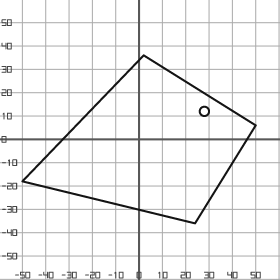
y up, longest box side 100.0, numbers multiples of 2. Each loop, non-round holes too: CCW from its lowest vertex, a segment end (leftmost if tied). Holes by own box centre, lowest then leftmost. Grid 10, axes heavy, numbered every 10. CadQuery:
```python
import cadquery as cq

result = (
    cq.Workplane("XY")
    .moveTo(24.0, -36.0)
    .lineTo(50.0, 6.0)
    .lineTo(2.0, 36.0)
    .lineTo(-50.0, -18.0)
    .close()
    .moveTo(28.0, 12.0)
    .circle(2.0)
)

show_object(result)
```